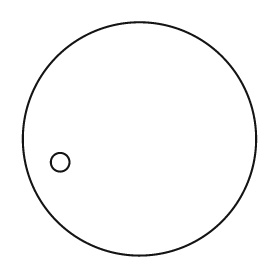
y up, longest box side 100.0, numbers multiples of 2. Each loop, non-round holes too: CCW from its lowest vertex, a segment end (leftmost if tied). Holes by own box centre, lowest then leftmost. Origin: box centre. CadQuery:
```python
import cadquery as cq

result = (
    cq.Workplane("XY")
    .moveTo(0.0, 0.0)
    .circle(50.0)
    .moveTo(-34.0, -10.0)
    .circle(4.0)
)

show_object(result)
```